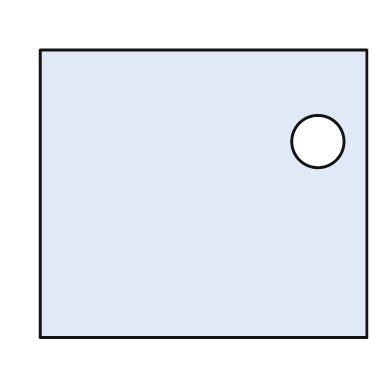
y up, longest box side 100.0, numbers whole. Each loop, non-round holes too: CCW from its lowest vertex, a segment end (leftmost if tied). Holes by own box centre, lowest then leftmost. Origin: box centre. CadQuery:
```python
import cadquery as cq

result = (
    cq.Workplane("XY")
    .moveTo(-50.0, -44.0)
    .lineTo(50.0, -44.0)
    .lineTo(50.0, 44.0)
    .lineTo(-50.0, 44.0)
    .close()
    .moveTo(35.0, 16.0)
    .circle(8.0)
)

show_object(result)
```